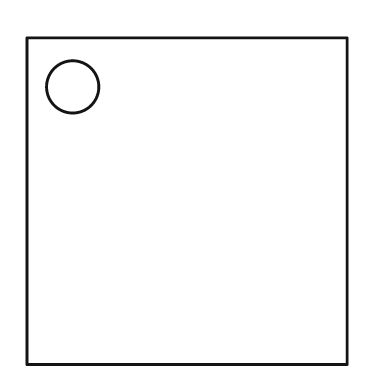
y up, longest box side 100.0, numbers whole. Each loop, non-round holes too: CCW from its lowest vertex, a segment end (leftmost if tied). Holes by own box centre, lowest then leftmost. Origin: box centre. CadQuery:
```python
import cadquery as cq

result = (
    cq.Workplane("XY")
    .moveTo(-49.0, -50.0)
    .lineTo(49.0, -50.0)
    .lineTo(49.0, 50.0)
    .lineTo(-49.0, 50.0)
    .close()
    .moveTo(-35.0, 35.0)
    .circle(8.0)
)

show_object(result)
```